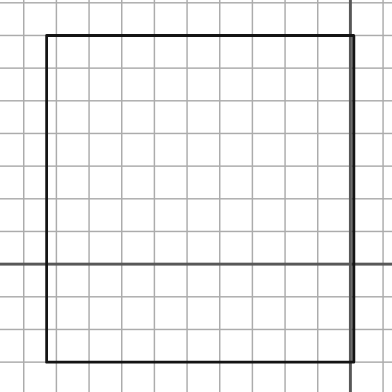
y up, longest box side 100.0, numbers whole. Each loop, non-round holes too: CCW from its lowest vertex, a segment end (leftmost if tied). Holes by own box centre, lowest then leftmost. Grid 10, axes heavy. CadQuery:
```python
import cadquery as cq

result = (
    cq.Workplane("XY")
    .moveTo(-93.0, -30.0)
    .lineTo(1.0, -30.0)
    .lineTo(1.0, 70.0)
    .lineTo(-93.0, 70.0)
    .close()
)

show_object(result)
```